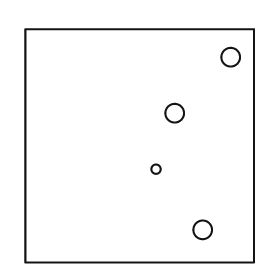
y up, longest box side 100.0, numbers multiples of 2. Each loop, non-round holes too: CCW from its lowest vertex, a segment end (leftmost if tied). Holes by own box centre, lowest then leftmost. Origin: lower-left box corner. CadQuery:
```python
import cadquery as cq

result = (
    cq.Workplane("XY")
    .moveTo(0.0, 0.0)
    .lineTo(98.0, 0.0)
    .lineTo(98.0, 100.0)
    .lineTo(0.0, 100.0)
    .close()
    .moveTo(76.0, 14.0)
    .circle(4.0)
    .moveTo(56.0, 40.0)
    .circle(2.0)
    .moveTo(64.0, 64.0)
    .circle(4.0)
    .moveTo(88.0, 88.0)
    .circle(4.0)
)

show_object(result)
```